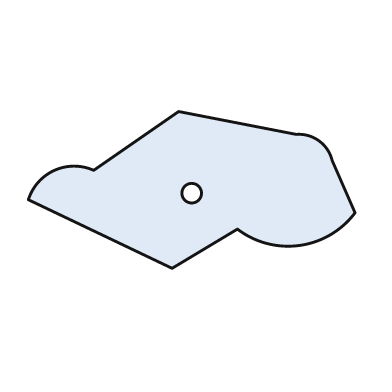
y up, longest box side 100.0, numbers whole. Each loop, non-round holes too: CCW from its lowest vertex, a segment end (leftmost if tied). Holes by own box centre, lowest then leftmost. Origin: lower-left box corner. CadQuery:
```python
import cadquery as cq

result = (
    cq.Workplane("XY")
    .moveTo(44.0, 0.0)
    .lineTo(64.0, 12.0)
    .threePointArc((83.0, 7.0), (100.0, 17.0))
    .lineTo(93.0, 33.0)
    .threePointArc((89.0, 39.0), (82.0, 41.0))
    .lineTo(46.0, 48.0)
    .lineTo(20.0, 30.0)
    .threePointArc((8.0, 30.0), (0.0, 21.0))
    .close()
    .moveTo(50.0, 23.0)
    .circle(3.0)
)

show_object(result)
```